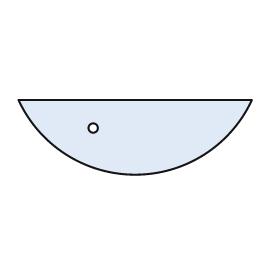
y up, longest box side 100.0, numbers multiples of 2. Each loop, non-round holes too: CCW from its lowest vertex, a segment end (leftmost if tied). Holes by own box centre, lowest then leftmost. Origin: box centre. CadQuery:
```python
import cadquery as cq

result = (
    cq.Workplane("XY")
    .moveTo(-50.0, 16.0)
    .threePointArc((0.0, -16.0), (50.0, 16.0))
    .close()
    .moveTo(-18.0, 4.0)
    .circle(2.0)
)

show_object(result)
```